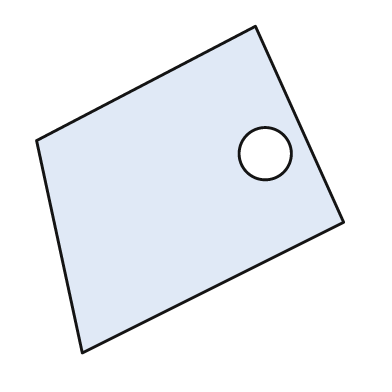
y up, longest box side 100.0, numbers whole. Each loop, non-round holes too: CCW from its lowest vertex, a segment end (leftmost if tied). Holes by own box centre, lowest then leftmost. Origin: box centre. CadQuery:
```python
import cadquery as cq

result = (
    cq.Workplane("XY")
    .moveTo(-33.0, -50.0)
    .lineTo(47.0, -10.0)
    .lineTo(20.0, 50.0)
    .lineTo(-47.0, 15.0)
    .close()
    .moveTo(23.0, 11.0)
    .circle(8.0)
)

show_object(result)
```